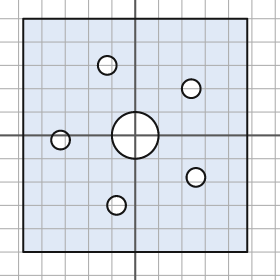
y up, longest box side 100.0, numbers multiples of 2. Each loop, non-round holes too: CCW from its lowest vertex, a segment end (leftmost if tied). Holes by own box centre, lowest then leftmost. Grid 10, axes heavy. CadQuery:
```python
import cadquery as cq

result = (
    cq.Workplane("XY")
    .moveTo(-48.0, -50.0)
    .lineTo(48.0, -50.0)
    .lineTo(48.0, 50.0)
    .lineTo(-48.0, 50.0)
    .close()
    .moveTo(-8.0, -30.0)
    .circle(4.0)
    .moveTo(26.0, -18.0)
    .circle(4.0)
    .moveTo(-32.0, -2.0)
    .circle(4.0)
    .moveTo(0.0, 0.0)
    .circle(10.0)
    .moveTo(24.0, 20.0)
    .circle(4.0)
    .moveTo(-12.0, 30.0)
    .circle(4.0)
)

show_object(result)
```